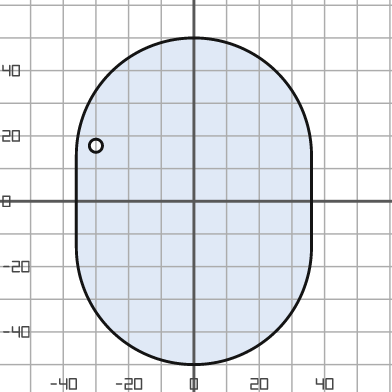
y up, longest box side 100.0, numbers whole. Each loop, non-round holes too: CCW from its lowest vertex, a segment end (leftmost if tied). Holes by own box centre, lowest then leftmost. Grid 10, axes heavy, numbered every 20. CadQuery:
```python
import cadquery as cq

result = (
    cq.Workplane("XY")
    .moveTo(-36.0, -14.0)
    .threePointArc((0.0, -50.0), (36.0, -14.0))
    .lineTo(36.0, 14.0)
    .threePointArc((0.0, 50.0), (-36.0, 14.0))
    .close()
    .moveTo(-30.0, 17.0)
    .circle(2.0)
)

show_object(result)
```